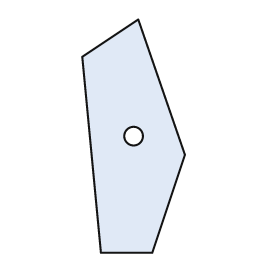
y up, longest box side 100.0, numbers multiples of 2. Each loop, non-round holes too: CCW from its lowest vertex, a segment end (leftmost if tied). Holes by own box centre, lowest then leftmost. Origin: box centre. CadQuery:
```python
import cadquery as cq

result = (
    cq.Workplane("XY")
    .moveTo(-14.0, -50.0)
    .lineTo(8.0, -50.0)
    .lineTo(22.0, -8.0)
    .lineTo(2.0, 50.0)
    .lineTo(-22.0, 34.0)
    .close()
    .moveTo(0.0, 0.0)
    .circle(4.0)
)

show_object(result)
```